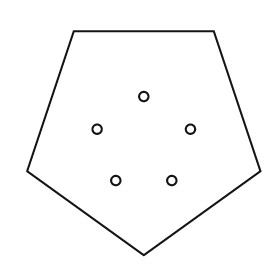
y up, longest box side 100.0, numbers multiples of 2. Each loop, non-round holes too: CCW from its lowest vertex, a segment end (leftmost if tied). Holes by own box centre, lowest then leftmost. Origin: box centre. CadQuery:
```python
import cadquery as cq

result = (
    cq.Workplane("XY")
    .moveTo(0.0, -48.0)
    .lineTo(50.0, -12.0)
    .lineTo(30.0, 48.0)
    .lineTo(-30.0, 48.0)
    .lineTo(-50.0, -12.0)
    .close()
    .moveTo(-12.0, -16.0)
    .circle(2.0)
    .moveTo(12.0, -16.0)
    .circle(2.0)
    .moveTo(-20.0, 6.0)
    .circle(2.0)
    .moveTo(20.0, 6.0)
    .circle(2.0)
    .moveTo(0.0, 20.0)
    .circle(2.0)
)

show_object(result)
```